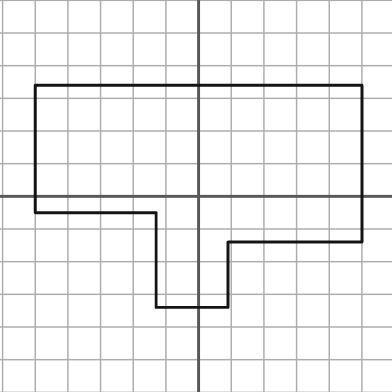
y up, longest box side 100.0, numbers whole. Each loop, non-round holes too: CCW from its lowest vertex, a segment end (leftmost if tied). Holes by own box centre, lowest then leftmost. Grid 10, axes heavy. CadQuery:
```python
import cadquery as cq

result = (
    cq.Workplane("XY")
    .moveTo(-13.0, -34.0)
    .lineTo(9.0, -34.0)
    .lineTo(9.0, -14.0)
    .lineTo(50.0, -14.0)
    .lineTo(50.0, 34.0)
    .lineTo(-50.0, 34.0)
    .lineTo(-50.0, -5.0)
    .lineTo(-13.0, -5.0)
    .close()
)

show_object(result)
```